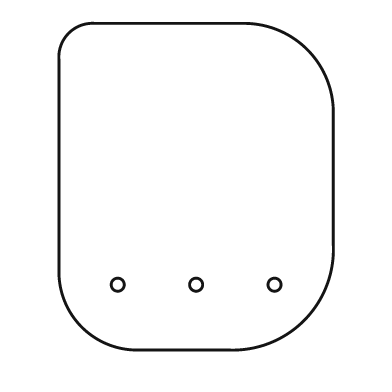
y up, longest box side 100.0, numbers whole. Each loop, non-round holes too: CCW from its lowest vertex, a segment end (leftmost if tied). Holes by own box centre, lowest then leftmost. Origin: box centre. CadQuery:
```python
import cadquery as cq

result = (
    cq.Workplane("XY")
    .moveTo(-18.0, -50.0)
    .lineTo(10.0, -50.0)
    .threePointArc((33.0, -41.0), (42.0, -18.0))
    .lineTo(42.0, 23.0)
    .threePointArc((34.0, 42.0), (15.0, 50.0))
    .lineTo(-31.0, 50.0)
    .threePointArc((-39.0, 47.0), (-42.0, 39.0))
    .lineTo(-42.0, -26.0)
    .threePointArc((-35.0, -43.0), (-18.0, -50.0))
    .close()
    .moveTo(-24.0, -30.0)
    .circle(2.0)
    .moveTo(0.0, -30.0)
    .circle(2.0)
    .moveTo(24.0, -30.0)
    .circle(2.0)
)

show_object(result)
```